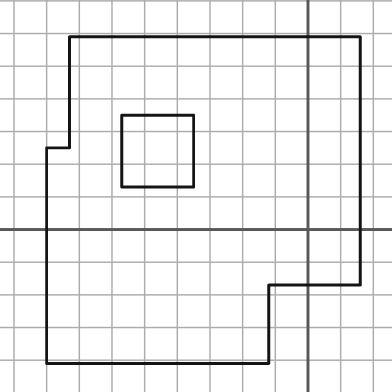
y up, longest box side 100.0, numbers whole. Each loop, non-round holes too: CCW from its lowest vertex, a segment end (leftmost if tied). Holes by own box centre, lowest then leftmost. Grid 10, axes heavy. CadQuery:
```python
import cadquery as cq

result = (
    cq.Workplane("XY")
    .moveTo(-80.0, -41.0)
    .lineTo(-12.0, -41.0)
    .lineTo(-12.0, -17.0)
    .lineTo(16.0, -17.0)
    .lineTo(16.0, 59.0)
    .lineTo(-73.0, 59.0)
    .lineTo(-73.0, 25.0)
    .lineTo(-80.0, 25.0)
    .close()
    .moveTo(-57.0, 13.0)
    .lineTo(-35.0, 13.0)
    .lineTo(-35.0, 35.0)
    .lineTo(-57.0, 35.0)
    .close()
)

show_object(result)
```